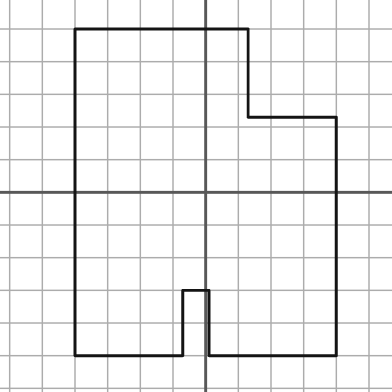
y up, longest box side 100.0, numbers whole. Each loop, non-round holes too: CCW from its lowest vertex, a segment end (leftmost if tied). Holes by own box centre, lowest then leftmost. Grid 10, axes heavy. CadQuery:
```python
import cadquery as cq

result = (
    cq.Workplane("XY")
    .moveTo(-40.0, -50.0)
    .lineTo(-7.0, -50.0)
    .lineTo(-7.0, -30.0)
    .lineTo(1.0, -30.0)
    .lineTo(1.0, -50.0)
    .lineTo(40.0, -50.0)
    .lineTo(40.0, 23.0)
    .lineTo(13.0, 23.0)
    .lineTo(13.0, 50.0)
    .lineTo(-40.0, 50.0)
    .close()
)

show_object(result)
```